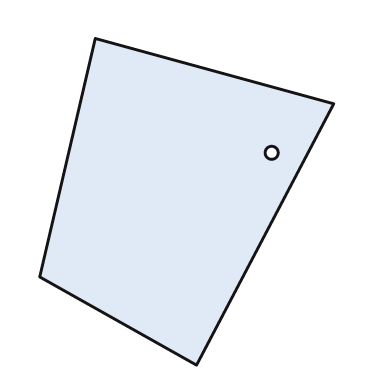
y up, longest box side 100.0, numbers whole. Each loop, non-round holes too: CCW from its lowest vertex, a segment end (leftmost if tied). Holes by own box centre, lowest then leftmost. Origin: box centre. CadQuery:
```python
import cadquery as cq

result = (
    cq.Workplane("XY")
    .moveTo(3.0, -50.0)
    .lineTo(45.0, 30.0)
    .lineTo(-28.0, 50.0)
    .lineTo(-45.0, -23.0)
    .close()
    .moveTo(26.0, 15.0)
    .circle(2.0)
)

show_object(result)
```